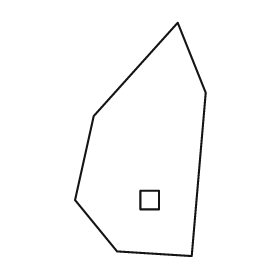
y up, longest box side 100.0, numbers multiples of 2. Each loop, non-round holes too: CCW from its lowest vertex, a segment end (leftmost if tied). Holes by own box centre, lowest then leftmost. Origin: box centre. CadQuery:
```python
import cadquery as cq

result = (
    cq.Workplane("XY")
    .moveTo(22.0, -50.0)
    .lineTo(28.0, 20.0)
    .lineTo(16.0, 50.0)
    .lineTo(-20.0, 10.0)
    .lineTo(-28.0, -26.0)
    .lineTo(-10.0, -48.0)
    .close()
    .moveTo(0.0, -30.0)
    .lineTo(8.0, -30.0)
    .lineTo(8.0, -22.0)
    .lineTo(0.0, -22.0)
    .close()
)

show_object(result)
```